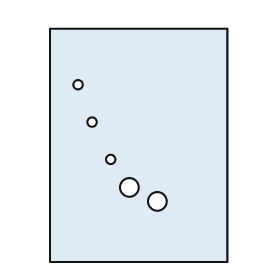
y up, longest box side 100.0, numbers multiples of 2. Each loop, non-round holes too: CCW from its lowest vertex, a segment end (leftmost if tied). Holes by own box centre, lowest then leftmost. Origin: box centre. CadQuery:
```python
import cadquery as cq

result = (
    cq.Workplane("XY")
    .moveTo(-38.0, -50.0)
    .lineTo(38.0, -50.0)
    .lineTo(38.0, 50.0)
    .lineTo(-38.0, 50.0)
    .close()
    .moveTo(8.0, -24.0)
    .circle(4.0)
    .moveTo(-4.0, -18.0)
    .circle(4.0)
    .moveTo(-12.0, -6.0)
    .circle(2.0)
    .moveTo(-20.0, 10.0)
    .circle(2.0)
    .moveTo(-26.0, 26.0)
    .circle(2.0)
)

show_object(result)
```